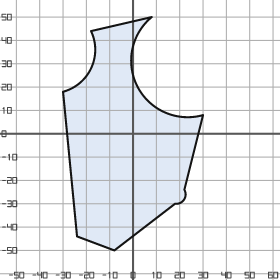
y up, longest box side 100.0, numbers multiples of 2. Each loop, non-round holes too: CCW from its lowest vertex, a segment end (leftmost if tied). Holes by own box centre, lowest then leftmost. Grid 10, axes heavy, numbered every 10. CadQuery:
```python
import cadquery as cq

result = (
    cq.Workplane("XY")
    .moveTo(-8.0, -50.0)
    .lineTo(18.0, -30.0)
    .threePointArc((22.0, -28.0), (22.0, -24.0))
    .lineTo(30.0, 8.0)
    .threePointArc((2.0, 20.0), (8.0, 50.0))
    .lineTo(-18.0, 44.0)
    .threePointArc((-18.0, 28.0), (-30.0, 18.0))
    .lineTo(-24.0, -44.0)
    .close()
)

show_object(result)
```